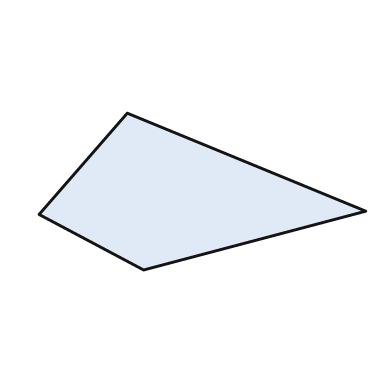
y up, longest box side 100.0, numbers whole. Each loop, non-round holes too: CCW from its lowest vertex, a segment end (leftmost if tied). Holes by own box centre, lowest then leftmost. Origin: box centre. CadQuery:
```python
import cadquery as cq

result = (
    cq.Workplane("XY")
    .moveTo(-18.0, -24.0)
    .lineTo(50.0, -6.0)
    .lineTo(-23.0, 24.0)
    .lineTo(-50.0, -7.0)
    .close()
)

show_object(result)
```